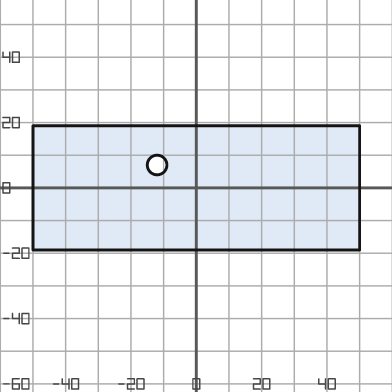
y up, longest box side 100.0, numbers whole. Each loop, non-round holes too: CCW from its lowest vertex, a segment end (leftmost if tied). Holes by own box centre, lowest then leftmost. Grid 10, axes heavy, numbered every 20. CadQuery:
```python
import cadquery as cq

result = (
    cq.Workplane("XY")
    .moveTo(-50.0, -19.0)
    .lineTo(50.0, -19.0)
    .lineTo(50.0, 19.0)
    .lineTo(-50.0, 19.0)
    .close()
    .moveTo(-12.0, 7.0)
    .circle(3.0)
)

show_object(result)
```